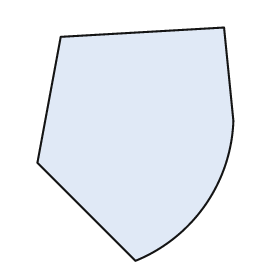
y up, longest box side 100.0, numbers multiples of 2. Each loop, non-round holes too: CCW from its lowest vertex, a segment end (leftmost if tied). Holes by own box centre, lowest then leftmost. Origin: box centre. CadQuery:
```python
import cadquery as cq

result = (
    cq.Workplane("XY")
    .moveTo(0.0, -50.0)
    .threePointArc((30.0, -26.0), (42.0, 10.0))
    .lineTo(38.0, 50.0)
    .lineTo(-32.0, 46.0)
    .lineTo(-42.0, -8.0)
    .close()
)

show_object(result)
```